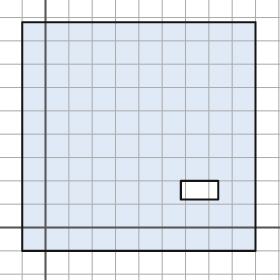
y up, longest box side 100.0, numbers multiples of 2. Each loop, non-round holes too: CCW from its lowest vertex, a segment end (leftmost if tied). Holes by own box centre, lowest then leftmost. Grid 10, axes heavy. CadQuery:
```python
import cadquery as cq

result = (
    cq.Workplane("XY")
    .moveTo(-10.0, -10.0)
    .lineTo(90.0, -10.0)
    .lineTo(90.0, 88.0)
    .lineTo(-10.0, 88.0)
    .close()
    .moveTo(58.0, 12.0)
    .lineTo(74.0, 12.0)
    .lineTo(74.0, 20.0)
    .lineTo(58.0, 20.0)
    .close()
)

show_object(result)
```